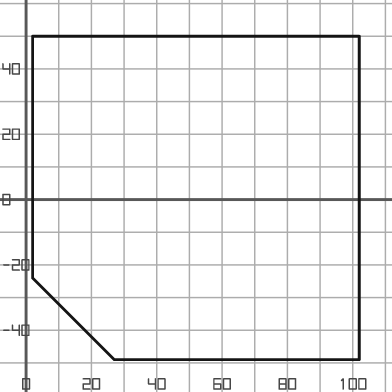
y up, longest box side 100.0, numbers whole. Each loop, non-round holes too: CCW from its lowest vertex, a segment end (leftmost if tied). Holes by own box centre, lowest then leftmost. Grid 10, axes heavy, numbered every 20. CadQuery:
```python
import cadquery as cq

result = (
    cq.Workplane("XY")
    .moveTo(27.0, -49.0)
    .lineTo(102.0, -49.0)
    .lineTo(102.0, 50.0)
    .lineTo(2.0, 50.0)
    .lineTo(2.0, -24.0)
    .close()
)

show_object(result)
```